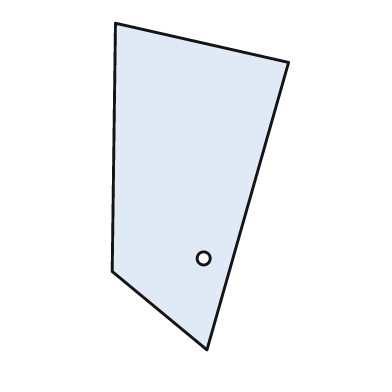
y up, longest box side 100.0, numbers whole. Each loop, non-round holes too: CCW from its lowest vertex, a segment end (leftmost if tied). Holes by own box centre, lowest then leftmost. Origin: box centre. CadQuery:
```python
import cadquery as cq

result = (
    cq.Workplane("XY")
    .moveTo(2.0, -50.0)
    .lineTo(27.0, 38.0)
    .lineTo(-26.0, 50.0)
    .lineTo(-27.0, -26.0)
    .close()
    .moveTo(1.0, -22.0)
    .circle(2.0)
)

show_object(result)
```